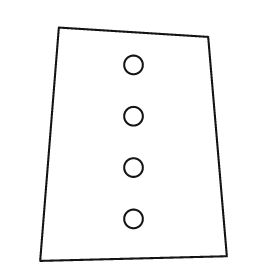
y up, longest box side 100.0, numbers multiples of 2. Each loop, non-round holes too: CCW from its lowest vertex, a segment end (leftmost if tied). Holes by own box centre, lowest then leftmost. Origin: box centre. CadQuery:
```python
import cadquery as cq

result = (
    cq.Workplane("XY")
    .moveTo(-40.0, -50.0)
    .lineTo(40.0, -48.0)
    .lineTo(32.0, 46.0)
    .lineTo(-32.0, 50.0)
    .close()
    .moveTo(0.0, -32.0)
    .circle(4.0)
    .moveTo(0.0, -10.0)
    .circle(4.0)
    .moveTo(0.0, 12.0)
    .circle(4.0)
    .moveTo(0.0, 34.0)
    .circle(4.0)
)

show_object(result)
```